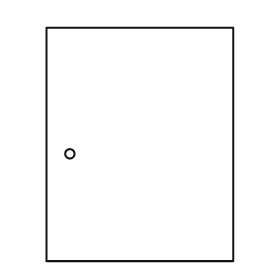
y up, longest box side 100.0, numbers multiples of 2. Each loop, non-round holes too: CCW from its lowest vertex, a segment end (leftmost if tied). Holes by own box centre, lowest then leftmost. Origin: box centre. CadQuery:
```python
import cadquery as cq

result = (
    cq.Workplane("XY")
    .moveTo(-40.0, -50.0)
    .lineTo(40.0, -50.0)
    .lineTo(40.0, 50.0)
    .lineTo(-40.0, 50.0)
    .close()
    .moveTo(-30.0, -4.0)
    .circle(2.0)
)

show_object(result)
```